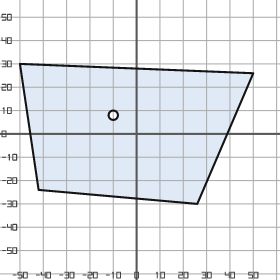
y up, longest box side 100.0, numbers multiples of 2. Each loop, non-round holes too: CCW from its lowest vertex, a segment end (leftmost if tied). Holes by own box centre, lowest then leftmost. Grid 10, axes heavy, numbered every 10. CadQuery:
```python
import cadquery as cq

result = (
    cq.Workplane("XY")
    .moveTo(26.0, -30.0)
    .lineTo(50.0, 26.0)
    .lineTo(-50.0, 30.0)
    .lineTo(-42.0, -24.0)
    .close()
    .moveTo(-10.0, 8.0)
    .circle(2.0)
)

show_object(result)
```